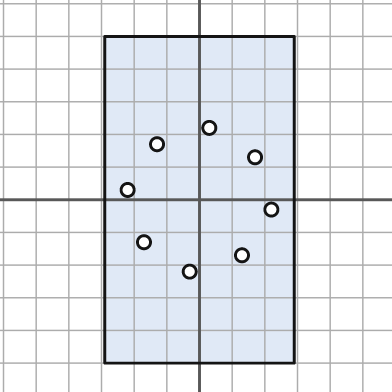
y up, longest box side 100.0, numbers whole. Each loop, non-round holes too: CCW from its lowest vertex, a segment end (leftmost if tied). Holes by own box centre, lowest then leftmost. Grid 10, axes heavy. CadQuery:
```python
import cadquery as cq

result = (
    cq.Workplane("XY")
    .moveTo(-29.0, -50.0)
    .lineTo(29.0, -50.0)
    .lineTo(29.0, 50.0)
    .lineTo(-29.0, 50.0)
    .close()
    .moveTo(-3.0, -22.0)
    .circle(2.0)
    .moveTo(13.0, -17.0)
    .circle(2.0)
    .moveTo(-17.0, -13.0)
    .circle(2.0)
    .moveTo(22.0, -3.0)
    .circle(2.0)
    .moveTo(-22.0, 3.0)
    .circle(2.0)
    .moveTo(17.0, 13.0)
    .circle(2.0)
    .moveTo(-13.0, 17.0)
    .circle(2.0)
    .moveTo(3.0, 22.0)
    .circle(2.0)
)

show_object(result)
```